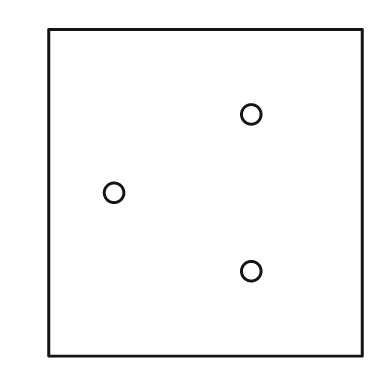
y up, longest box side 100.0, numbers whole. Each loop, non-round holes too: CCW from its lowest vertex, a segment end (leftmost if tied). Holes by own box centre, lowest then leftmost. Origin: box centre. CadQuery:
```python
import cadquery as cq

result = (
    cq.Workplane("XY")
    .moveTo(-48.0, -50.0)
    .lineTo(48.0, -50.0)
    .lineTo(48.0, 50.0)
    .lineTo(-48.0, 50.0)
    .close()
    .moveTo(14.0, -24.0)
    .circle(3.0)
    .moveTo(-28.0, 0.0)
    .circle(3.0)
    .moveTo(14.0, 24.0)
    .circle(3.0)
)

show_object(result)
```